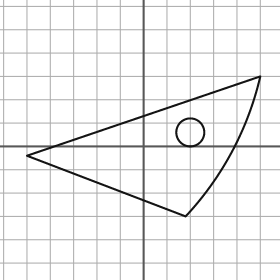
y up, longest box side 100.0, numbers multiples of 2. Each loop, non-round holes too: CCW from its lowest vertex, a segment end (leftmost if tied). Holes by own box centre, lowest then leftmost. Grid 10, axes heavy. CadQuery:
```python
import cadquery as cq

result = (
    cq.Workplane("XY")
    .moveTo(18.0, -30.0)
    .threePointArc((38.0, -2.0), (50.0, 30.0))
    .lineTo(-50.0, -4.0)
    .close()
    .moveTo(20.0, 6.0)
    .circle(6.0)
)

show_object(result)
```